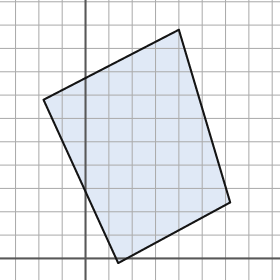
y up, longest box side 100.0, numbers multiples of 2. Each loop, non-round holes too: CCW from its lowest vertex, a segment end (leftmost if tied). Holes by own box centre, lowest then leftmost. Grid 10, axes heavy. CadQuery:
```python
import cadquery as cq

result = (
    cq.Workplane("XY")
    .moveTo(14.0, -2.0)
    .lineTo(62.0, 24.0)
    .lineTo(40.0, 98.0)
    .lineTo(-18.0, 68.0)
    .close()
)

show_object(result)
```